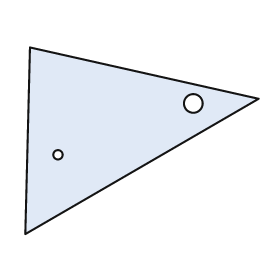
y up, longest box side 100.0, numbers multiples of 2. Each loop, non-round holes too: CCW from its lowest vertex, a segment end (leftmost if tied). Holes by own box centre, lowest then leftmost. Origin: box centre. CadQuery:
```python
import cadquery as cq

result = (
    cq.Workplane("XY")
    .moveTo(-50.0, -40.0)
    .lineTo(50.0, 18.0)
    .lineTo(-48.0, 40.0)
    .close()
    .moveTo(-36.0, -6.0)
    .circle(2.0)
    .moveTo(22.0, 16.0)
    .circle(4.0)
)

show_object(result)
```